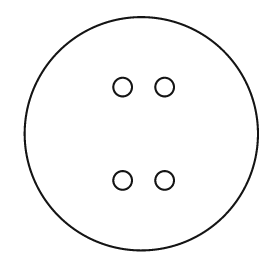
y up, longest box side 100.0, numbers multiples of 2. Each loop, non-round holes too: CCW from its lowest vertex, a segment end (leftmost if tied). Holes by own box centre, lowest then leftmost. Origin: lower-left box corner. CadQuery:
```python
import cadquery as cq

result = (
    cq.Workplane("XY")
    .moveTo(50.0, 50.0)
    .circle(50.0)
    .moveTo(42.0, 30.0)
    .circle(4.0)
    .moveTo(60.0, 30.0)
    .circle(4.0)
    .moveTo(42.0, 70.0)
    .circle(4.0)
    .moveTo(60.0, 70.0)
    .circle(4.0)
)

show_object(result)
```